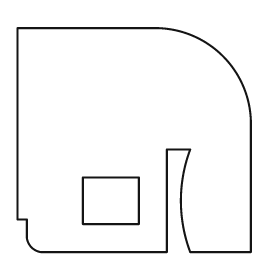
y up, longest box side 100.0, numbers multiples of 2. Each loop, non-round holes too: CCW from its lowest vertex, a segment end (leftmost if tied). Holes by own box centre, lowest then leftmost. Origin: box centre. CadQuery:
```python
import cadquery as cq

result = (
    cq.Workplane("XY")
    .moveTo(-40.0, -48.0)
    .lineTo(14.0, -48.0)
    .lineTo(14.0, -4.0)
    .lineTo(24.0, -4.0)
    .threePointArc((20.0, -26.0), (24.0, -48.0))
    .lineTo(50.0, -48.0)
    .lineTo(50.0, 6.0)
    .threePointArc((38.0, 36.0), (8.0, 48.0))
    .lineTo(-50.0, 48.0)
    .lineTo(-50.0, -34.0)
    .lineTo(-46.0, -34.0)
    .lineTo(-46.0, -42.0)
    .threePointArc((-44.0, -46.0), (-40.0, -48.0))
    .close()
    .moveTo(-22.0, -36.0)
    .lineTo(2.0, -36.0)
    .lineTo(2.0, -16.0)
    .lineTo(-22.0, -16.0)
    .close()
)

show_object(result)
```